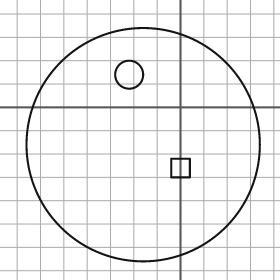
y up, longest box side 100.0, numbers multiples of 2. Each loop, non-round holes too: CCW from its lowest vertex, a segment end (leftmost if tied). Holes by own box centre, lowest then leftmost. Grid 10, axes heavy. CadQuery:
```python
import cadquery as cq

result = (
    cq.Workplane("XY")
    .moveTo(-16.0, -16.0)
    .circle(50.0)
    .moveTo(-4.0, -30.0)
    .lineTo(4.0, -30.0)
    .lineTo(4.0, -22.0)
    .lineTo(-4.0, -22.0)
    .close()
    .moveTo(-22.0, 14.0)
    .circle(6.0)
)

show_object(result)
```